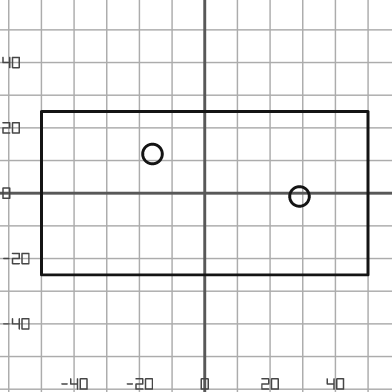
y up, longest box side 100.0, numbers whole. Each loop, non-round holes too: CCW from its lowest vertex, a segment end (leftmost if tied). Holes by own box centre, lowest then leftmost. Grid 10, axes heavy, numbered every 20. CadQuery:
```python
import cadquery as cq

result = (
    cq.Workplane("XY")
    .moveTo(-50.0, -25.0)
    .lineTo(50.0, -25.0)
    .lineTo(50.0, 25.0)
    .lineTo(-50.0, 25.0)
    .close()
    .moveTo(29.0, -1.0)
    .circle(3.0)
    .moveTo(-16.0, 12.0)
    .circle(3.0)
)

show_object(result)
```